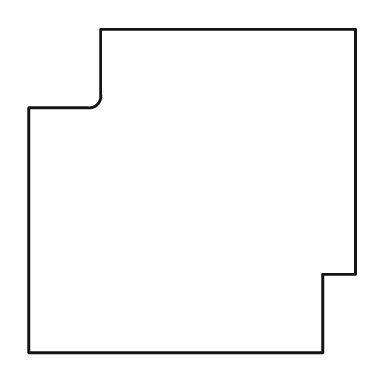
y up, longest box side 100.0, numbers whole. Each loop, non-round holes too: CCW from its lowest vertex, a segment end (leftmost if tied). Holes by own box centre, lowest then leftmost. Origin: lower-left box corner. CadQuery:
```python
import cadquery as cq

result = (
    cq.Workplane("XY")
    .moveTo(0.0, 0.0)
    .lineTo(90.0, 0.0)
    .lineTo(90.0, 24.0)
    .lineTo(100.0, 24.0)
    .lineTo(100.0, 99.0)
    .lineTo(22.0, 99.0)
    .lineTo(22.0, 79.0)
    .threePointArc((21.0, 76.0), (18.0, 75.0))
    .lineTo(0.0, 75.0)
    .close()
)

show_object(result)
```